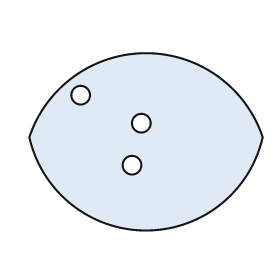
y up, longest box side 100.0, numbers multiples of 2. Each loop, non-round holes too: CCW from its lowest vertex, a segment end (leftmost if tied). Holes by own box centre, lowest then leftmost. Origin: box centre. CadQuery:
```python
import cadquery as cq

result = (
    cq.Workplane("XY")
    .moveTo(-50.0, 2.0)
    .threePointArc((0.0, -38.0), (50.0, 2.0))
    .threePointArc((0.0, 38.0), (-50.0, 2.0))
    .close()
    .moveTo(-6.0, -10.0)
    .circle(4.0)
    .moveTo(-2.0, 8.0)
    .circle(4.0)
    .moveTo(-28.0, 20.0)
    .circle(4.0)
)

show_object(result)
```